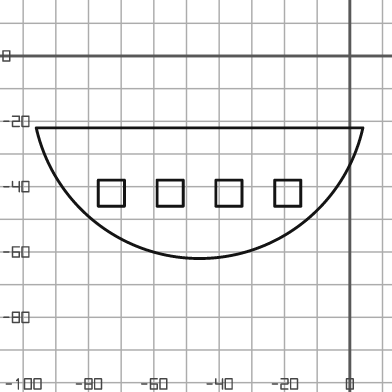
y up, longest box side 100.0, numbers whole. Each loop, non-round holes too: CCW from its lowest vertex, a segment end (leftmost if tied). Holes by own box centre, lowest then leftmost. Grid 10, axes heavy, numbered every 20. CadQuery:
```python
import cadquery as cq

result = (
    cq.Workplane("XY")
    .moveTo(-96.0, -22.0)
    .threePointArc((-46.0, -62.0), (4.0, -22.0))
    .close()
    .moveTo(-77.0, -46.0)
    .lineTo(-69.0, -46.0)
    .lineTo(-69.0, -38.0)
    .lineTo(-77.0, -38.0)
    .close()
    .moveTo(-59.0, -46.0)
    .lineTo(-51.0, -46.0)
    .lineTo(-51.0, -38.0)
    .lineTo(-59.0, -38.0)
    .close()
    .moveTo(-41.0, -46.0)
    .lineTo(-33.0, -46.0)
    .lineTo(-33.0, -38.0)
    .lineTo(-41.0, -38.0)
    .close()
    .moveTo(-23.0, -46.0)
    .lineTo(-15.0, -46.0)
    .lineTo(-15.0, -38.0)
    .lineTo(-23.0, -38.0)
    .close()
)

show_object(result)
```